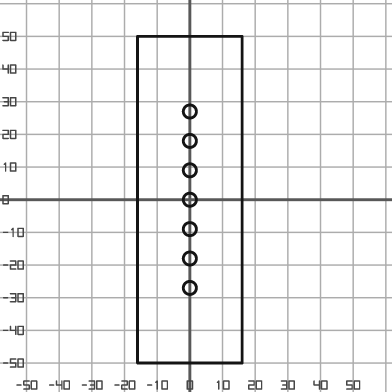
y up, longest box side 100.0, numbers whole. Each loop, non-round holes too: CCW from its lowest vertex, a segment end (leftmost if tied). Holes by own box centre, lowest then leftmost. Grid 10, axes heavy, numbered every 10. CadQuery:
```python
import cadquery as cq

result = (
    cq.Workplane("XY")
    .moveTo(-16.0, -50.0)
    .lineTo(16.0, -50.0)
    .lineTo(16.0, 50.0)
    .lineTo(-16.0, 50.0)
    .close()
    .moveTo(0.0, -27.0)
    .circle(2.0)
    .moveTo(0.0, -18.0)
    .circle(2.0)
    .moveTo(0.0, -9.0)
    .circle(2.0)
    .moveTo(0.0, 0.0)
    .circle(2.0)
    .moveTo(0.0, 9.0)
    .circle(2.0)
    .moveTo(0.0, 18.0)
    .circle(2.0)
    .moveTo(0.0, 27.0)
    .circle(2.0)
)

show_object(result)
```